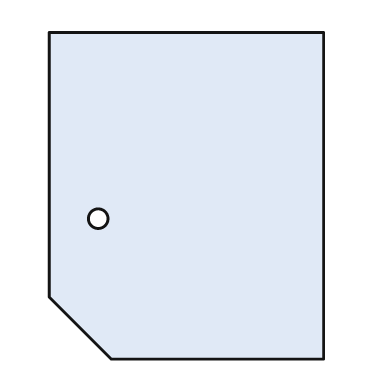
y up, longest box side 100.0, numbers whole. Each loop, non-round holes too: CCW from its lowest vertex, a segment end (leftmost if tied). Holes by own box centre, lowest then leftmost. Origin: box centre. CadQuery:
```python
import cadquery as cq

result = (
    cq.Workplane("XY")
    .moveTo(-23.0, -50.0)
    .lineTo(42.0, -50.0)
    .lineTo(42.0, 50.0)
    .lineTo(-42.0, 50.0)
    .lineTo(-42.0, -31.0)
    .close()
    .moveTo(-27.0, -7.0)
    .circle(3.0)
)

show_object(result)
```